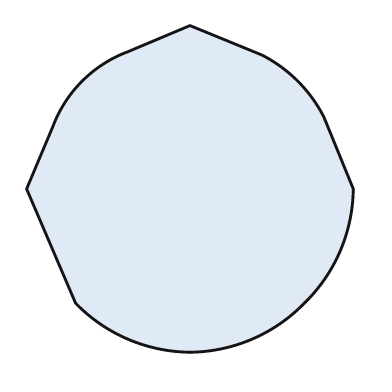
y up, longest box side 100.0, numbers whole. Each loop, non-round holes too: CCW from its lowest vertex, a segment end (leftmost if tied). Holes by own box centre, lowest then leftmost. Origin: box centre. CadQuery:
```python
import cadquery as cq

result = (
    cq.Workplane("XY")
    .moveTo(0.0, -50.0)
    .threePointArc((19.0, -46.0), (35.0, -35.0))
    .threePointArc((46.0, -19.0), (50.0, 0.0))
    .lineTo(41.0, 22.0)
    .threePointArc((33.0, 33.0), (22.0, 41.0))
    .lineTo(0.0, 50.0)
    .lineTo(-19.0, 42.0)
    .threePointArc((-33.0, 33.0), (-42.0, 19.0))
    .lineTo(-50.0, 0.0)
    .lineTo(-35.0, -35.0)
    .threePointArc((-19.0, -46.0), (0.0, -50.0))
    .close()
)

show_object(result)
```